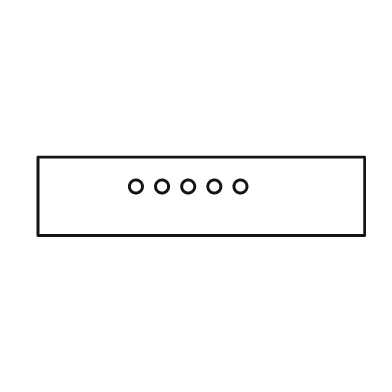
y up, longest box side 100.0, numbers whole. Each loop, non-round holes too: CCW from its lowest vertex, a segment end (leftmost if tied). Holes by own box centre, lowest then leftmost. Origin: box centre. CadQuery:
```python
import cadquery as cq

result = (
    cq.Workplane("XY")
    .moveTo(-50.0, -12.0)
    .lineTo(50.0, -12.0)
    .lineTo(50.0, 12.0)
    .lineTo(-50.0, 12.0)
    .close()
    .moveTo(-20.0, 3.0)
    .circle(2.0)
    .moveTo(-12.0, 3.0)
    .circle(2.0)
    .moveTo(-4.0, 3.0)
    .circle(2.0)
    .moveTo(4.0, 3.0)
    .circle(2.0)
    .moveTo(12.0, 3.0)
    .circle(2.0)
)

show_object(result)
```